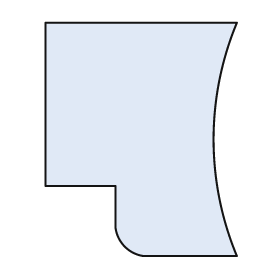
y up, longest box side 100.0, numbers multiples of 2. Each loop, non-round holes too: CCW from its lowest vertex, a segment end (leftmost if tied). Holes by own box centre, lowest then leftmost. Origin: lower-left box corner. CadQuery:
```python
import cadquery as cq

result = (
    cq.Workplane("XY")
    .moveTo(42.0, 0.0)
    .lineTo(82.0, 0.0)
    .threePointArc((72.0, 50.0), (82.0, 100.0))
    .lineTo(0.0, 100.0)
    .lineTo(0.0, 30.0)
    .lineTo(30.0, 30.0)
    .lineTo(30.0, 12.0)
    .threePointArc((34.0, 4.0), (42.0, 0.0))
    .close()
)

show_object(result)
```